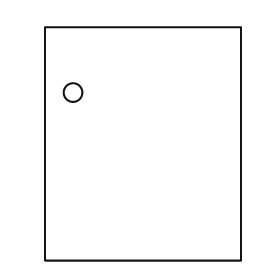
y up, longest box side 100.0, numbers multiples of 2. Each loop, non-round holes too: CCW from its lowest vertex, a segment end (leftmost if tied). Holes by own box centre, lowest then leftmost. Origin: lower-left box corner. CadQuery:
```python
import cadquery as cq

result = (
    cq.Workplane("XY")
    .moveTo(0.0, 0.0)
    .lineTo(84.0, 0.0)
    .lineTo(84.0, 100.0)
    .lineTo(0.0, 100.0)
    .close()
    .moveTo(12.0, 72.0)
    .circle(4.0)
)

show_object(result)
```